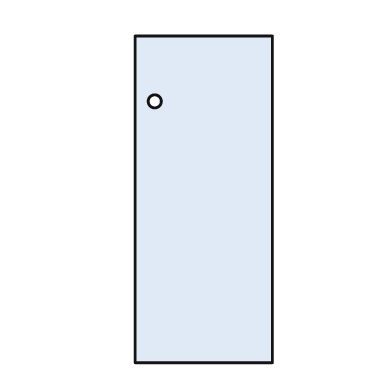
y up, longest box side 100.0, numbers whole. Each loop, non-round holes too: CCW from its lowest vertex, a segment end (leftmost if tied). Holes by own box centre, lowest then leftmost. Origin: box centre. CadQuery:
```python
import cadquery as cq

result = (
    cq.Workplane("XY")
    .moveTo(-21.0, -50.0)
    .lineTo(21.0, -50.0)
    .lineTo(21.0, 50.0)
    .lineTo(-21.0, 50.0)
    .close()
    .moveTo(-15.0, 30.0)
    .circle(2.0)
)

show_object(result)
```